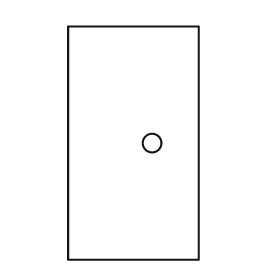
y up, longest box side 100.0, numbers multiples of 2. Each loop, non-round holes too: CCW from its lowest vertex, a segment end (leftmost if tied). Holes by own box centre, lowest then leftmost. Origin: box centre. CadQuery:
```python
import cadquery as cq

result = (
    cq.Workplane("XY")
    .moveTo(-28.0, -50.0)
    .lineTo(28.0, -50.0)
    .lineTo(28.0, 50.0)
    .lineTo(-28.0, 50.0)
    .close()
    .moveTo(8.0, 0.0)
    .circle(4.0)
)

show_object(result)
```